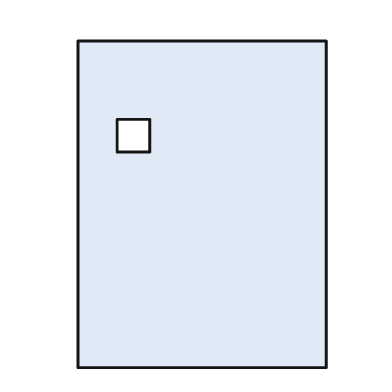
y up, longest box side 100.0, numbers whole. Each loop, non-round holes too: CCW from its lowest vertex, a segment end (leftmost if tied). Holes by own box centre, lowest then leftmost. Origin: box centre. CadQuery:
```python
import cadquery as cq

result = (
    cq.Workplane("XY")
    .moveTo(-38.0, -50.0)
    .lineTo(38.0, -50.0)
    .lineTo(38.0, 50.0)
    .lineTo(-38.0, 50.0)
    .close()
    .moveTo(-26.0, 16.0)
    .lineTo(-16.0, 16.0)
    .lineTo(-16.0, 26.0)
    .lineTo(-26.0, 26.0)
    .close()
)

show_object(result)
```